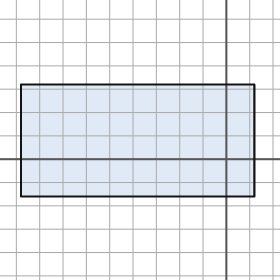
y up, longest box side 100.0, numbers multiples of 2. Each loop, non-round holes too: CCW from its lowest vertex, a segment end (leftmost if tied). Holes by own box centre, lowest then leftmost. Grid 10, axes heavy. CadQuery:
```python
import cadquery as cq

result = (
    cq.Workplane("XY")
    .moveTo(-88.0, -16.0)
    .lineTo(12.0, -16.0)
    .lineTo(12.0, 32.0)
    .lineTo(-88.0, 32.0)
    .close()
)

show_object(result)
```